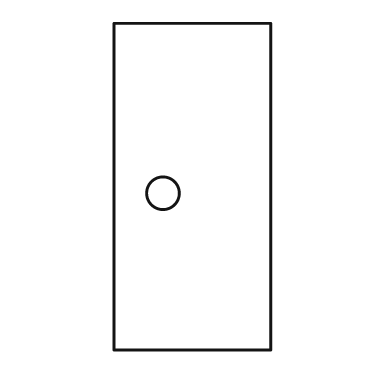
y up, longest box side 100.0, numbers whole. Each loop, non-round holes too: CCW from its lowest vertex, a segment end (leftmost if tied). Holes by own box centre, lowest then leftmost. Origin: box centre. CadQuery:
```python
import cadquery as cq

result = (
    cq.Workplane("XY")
    .moveTo(-24.0, -50.0)
    .lineTo(24.0, -50.0)
    .lineTo(24.0, 50.0)
    .lineTo(-24.0, 50.0)
    .close()
    .moveTo(-9.0, -2.0)
    .circle(5.0)
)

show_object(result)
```